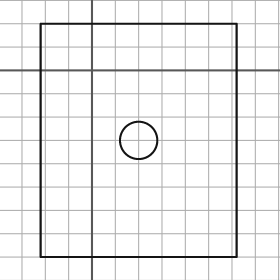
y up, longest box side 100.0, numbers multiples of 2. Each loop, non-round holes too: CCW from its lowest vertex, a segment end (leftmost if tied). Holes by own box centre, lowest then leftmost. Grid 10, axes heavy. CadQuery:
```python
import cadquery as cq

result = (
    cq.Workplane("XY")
    .moveTo(-22.0, -80.0)
    .lineTo(62.0, -80.0)
    .lineTo(62.0, 20.0)
    .lineTo(-22.0, 20.0)
    .close()
    .moveTo(20.0, -30.0)
    .circle(8.0)
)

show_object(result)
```